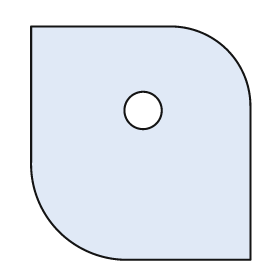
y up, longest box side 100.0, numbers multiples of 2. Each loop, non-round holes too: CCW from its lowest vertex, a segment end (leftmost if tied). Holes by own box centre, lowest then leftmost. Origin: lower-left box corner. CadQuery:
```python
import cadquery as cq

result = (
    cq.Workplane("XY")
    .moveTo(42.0, 0.0)
    .lineTo(94.0, 0.0)
    .lineTo(94.0, 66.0)
    .threePointArc((84.0, 90.0), (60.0, 100.0))
    .lineTo(0.0, 100.0)
    .lineTo(0.0, 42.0)
    .threePointArc((12.0, 12.0), (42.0, 0.0))
    .close()
    .moveTo(48.0, 64.0)
    .circle(8.0)
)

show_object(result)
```